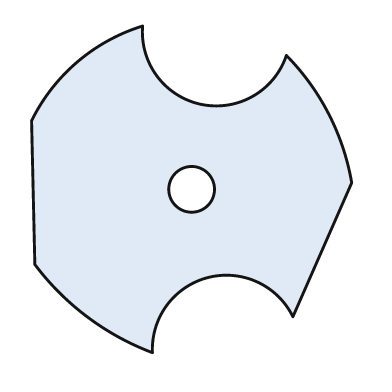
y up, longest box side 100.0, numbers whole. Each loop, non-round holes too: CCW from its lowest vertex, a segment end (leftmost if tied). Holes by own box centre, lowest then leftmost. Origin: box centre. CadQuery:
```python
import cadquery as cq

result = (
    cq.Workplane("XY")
    .moveTo(-12.0, -50.0)
    .threePointArc((5.0, -27.0), (31.0, -39.0))
    .lineTo(49.0, 2.0)
    .threePointArc((42.0, 23.0), (29.0, 41.0))
    .threePointArc((3.0, 26.0), (-15.0, 50.0))
    .threePointArc((-35.0, 39.0), (-49.0, 21.0))
    .lineTo(-48.0, -23.0)
    .threePointArc((-32.0, -39.0), (-12.0, -50.0))
    .close()
    .moveTo(0.0, 0.0)
    .circle(7.0)
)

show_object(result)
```